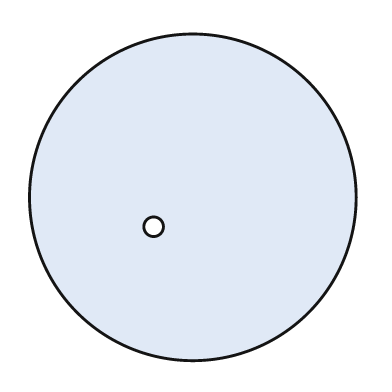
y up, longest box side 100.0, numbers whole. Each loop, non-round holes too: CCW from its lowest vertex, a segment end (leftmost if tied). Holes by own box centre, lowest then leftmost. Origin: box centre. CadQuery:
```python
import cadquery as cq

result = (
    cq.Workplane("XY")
    .moveTo(0.0, 0.0)
    .circle(50.0)
    .moveTo(-12.0, -9.0)
    .circle(3.0)
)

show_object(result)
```